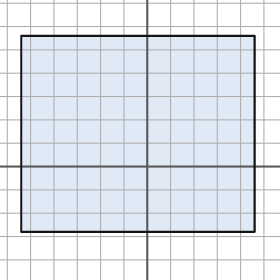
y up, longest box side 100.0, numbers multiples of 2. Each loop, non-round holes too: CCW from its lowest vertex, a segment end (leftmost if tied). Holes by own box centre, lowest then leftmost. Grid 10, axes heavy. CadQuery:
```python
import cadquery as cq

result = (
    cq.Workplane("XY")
    .moveTo(-54.0, -28.0)
    .lineTo(46.0, -28.0)
    .lineTo(46.0, 56.0)
    .lineTo(-54.0, 56.0)
    .close()
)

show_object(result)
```